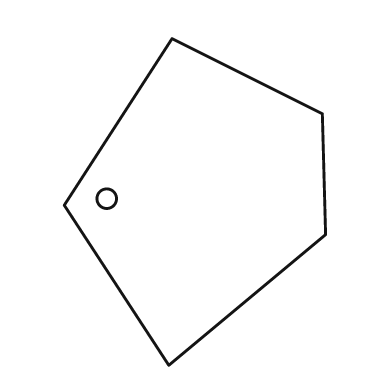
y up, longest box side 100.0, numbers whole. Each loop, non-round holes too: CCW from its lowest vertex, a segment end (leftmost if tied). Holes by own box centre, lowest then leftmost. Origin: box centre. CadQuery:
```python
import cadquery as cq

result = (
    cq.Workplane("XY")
    .moveTo(-8.0, -50.0)
    .lineTo(40.0, -10.0)
    .lineTo(39.0, 27.0)
    .lineTo(-7.0, 50.0)
    .lineTo(-40.0, -1.0)
    .close()
    .moveTo(-27.0, 1.0)
    .circle(3.0)
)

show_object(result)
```